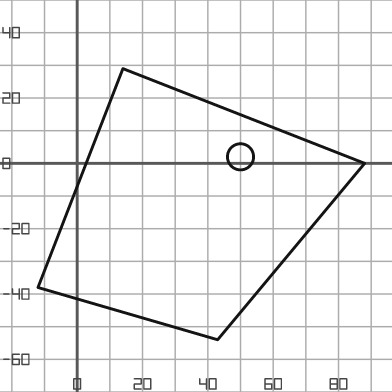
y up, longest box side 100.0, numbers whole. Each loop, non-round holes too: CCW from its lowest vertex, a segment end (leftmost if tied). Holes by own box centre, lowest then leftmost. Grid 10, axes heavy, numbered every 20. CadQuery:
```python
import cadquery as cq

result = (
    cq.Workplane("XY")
    .moveTo(43.0, -54.0)
    .lineTo(88.0, 0.0)
    .lineTo(14.0, 29.0)
    .lineTo(-12.0, -38.0)
    .close()
    .moveTo(50.0, 2.0)
    .circle(4.0)
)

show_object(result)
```